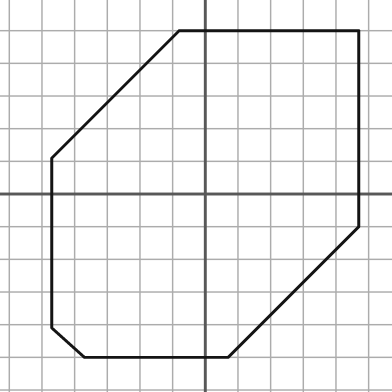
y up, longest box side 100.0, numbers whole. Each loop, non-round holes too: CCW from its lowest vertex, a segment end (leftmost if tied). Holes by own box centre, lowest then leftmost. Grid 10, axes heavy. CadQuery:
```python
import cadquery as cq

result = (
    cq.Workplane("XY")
    .moveTo(-37.0, -50.0)
    .lineTo(7.0, -50.0)
    .lineTo(47.0, -10.0)
    .lineTo(47.0, 50.0)
    .lineTo(-8.0, 50.0)
    .lineTo(-47.0, 11.0)
    .lineTo(-47.0, -41.0)
    .close()
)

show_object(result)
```